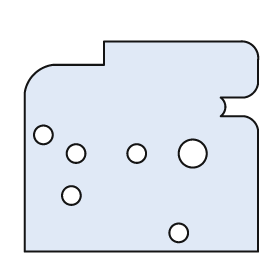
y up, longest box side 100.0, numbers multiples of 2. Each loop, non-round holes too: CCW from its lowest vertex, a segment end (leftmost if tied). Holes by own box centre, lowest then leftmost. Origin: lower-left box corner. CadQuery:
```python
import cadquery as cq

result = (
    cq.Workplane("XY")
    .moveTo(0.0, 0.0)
    .lineTo(100.0, 0.0)
    .lineTo(100.0, 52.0)
    .threePointArc((98.0, 56.0), (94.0, 58.0))
    .lineTo(84.0, 58.0)
    .threePointArc((86.0, 62.0), (84.0, 66.0))
    .lineTo(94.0, 66.0)
    .threePointArc((98.0, 68.0), (100.0, 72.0))
    .lineTo(100.0, 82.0)
    .threePointArc((98.0, 88.0), (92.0, 90.0))
    .lineTo(34.0, 90.0)
    .lineTo(34.0, 80.0)
    .lineTo(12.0, 80.0)
    .threePointArc((4.0, 76.0), (0.0, 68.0))
    .close()
    .moveTo(66.0, 8.0)
    .circle(4.0)
    .moveTo(20.0, 24.0)
    .circle(4.0)
    .moveTo(22.0, 42.0)
    .circle(4.0)
    .moveTo(48.0, 42.0)
    .circle(4.0)
    .moveTo(72.0, 42.0)
    .circle(6.0)
    .moveTo(8.0, 50.0)
    .circle(4.0)
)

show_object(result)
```